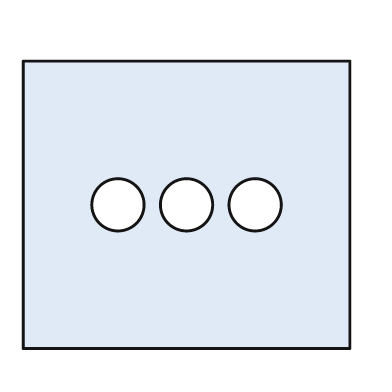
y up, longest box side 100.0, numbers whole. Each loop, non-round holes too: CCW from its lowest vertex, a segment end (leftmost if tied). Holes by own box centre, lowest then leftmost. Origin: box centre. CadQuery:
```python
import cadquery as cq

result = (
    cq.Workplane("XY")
    .moveTo(-50.0, -44.0)
    .lineTo(50.0, -44.0)
    .lineTo(50.0, 44.0)
    .lineTo(-50.0, 44.0)
    .close()
    .moveTo(-21.0, 0.0)
    .circle(8.0)
    .moveTo(0.0, 0.0)
    .circle(8.0)
    .moveTo(21.0, 0.0)
    .circle(8.0)
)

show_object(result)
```